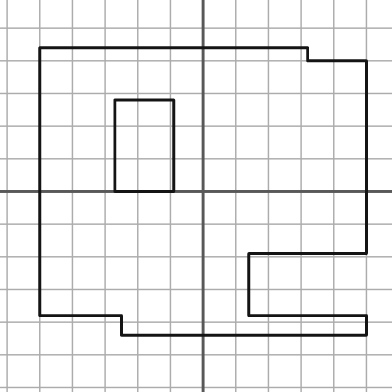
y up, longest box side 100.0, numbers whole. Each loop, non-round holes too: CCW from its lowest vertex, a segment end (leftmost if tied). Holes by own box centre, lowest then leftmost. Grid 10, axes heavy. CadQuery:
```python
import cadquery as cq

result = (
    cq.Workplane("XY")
    .moveTo(-25.0, -44.0)
    .lineTo(50.0, -44.0)
    .lineTo(50.0, -38.0)
    .lineTo(14.0, -38.0)
    .lineTo(14.0, -19.0)
    .lineTo(50.0, -19.0)
    .lineTo(50.0, 40.0)
    .lineTo(32.0, 40.0)
    .lineTo(32.0, 44.0)
    .lineTo(-50.0, 44.0)
    .lineTo(-50.0, -38.0)
    .lineTo(-25.0, -38.0)
    .close()
    .moveTo(-27.0, 0.0)
    .lineTo(-9.0, 0.0)
    .lineTo(-9.0, 28.0)
    .lineTo(-27.0, 28.0)
    .close()
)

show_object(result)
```